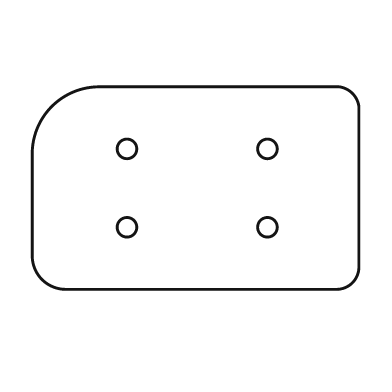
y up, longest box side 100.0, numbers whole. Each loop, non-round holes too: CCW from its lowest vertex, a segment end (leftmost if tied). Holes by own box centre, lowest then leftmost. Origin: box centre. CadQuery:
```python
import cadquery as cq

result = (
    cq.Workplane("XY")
    .moveTo(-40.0, -31.0)
    .lineTo(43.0, -31.0)
    .threePointArc((48.0, -29.0), (50.0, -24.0))
    .lineTo(50.0, 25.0)
    .threePointArc((48.0, 29.0), (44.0, 31.0))
    .lineTo(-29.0, 31.0)
    .threePointArc((-44.0, 25.0), (-50.0, 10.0))
    .lineTo(-50.0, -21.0)
    .threePointArc((-47.0, -28.0), (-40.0, -31.0))
    .close()
    .moveTo(-21.0, -12.0)
    .circle(3.0)
    .moveTo(22.0, -12.0)
    .circle(3.0)
    .moveTo(-21.0, 12.0)
    .circle(3.0)
    .moveTo(22.0, 12.0)
    .circle(3.0)
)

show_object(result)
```